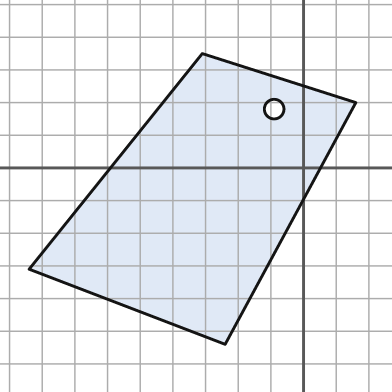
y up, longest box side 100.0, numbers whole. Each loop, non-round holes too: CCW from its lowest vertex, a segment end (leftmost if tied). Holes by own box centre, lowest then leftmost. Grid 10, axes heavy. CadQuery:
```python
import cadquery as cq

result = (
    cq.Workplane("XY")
    .moveTo(-24.0, -54.0)
    .lineTo(16.0, 20.0)
    .lineTo(-31.0, 35.0)
    .lineTo(-84.0, -31.0)
    .close()
    .moveTo(-9.0, 18.0)
    .circle(3.0)
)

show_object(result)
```